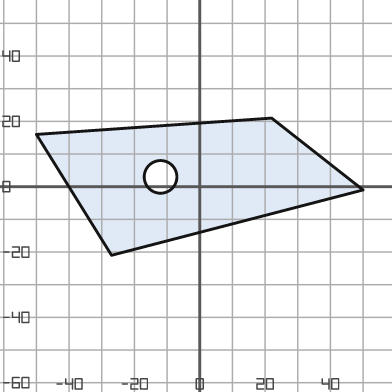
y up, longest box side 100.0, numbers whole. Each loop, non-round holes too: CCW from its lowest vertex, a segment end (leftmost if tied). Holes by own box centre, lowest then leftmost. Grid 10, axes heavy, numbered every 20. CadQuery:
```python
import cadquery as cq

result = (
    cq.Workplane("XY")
    .moveTo(-27.0, -21.0)
    .lineTo(50.0, -1.0)
    .lineTo(22.0, 21.0)
    .lineTo(-50.0, 16.0)
    .close()
    .moveTo(-12.0, 3.0)
    .circle(5.0)
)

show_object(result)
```